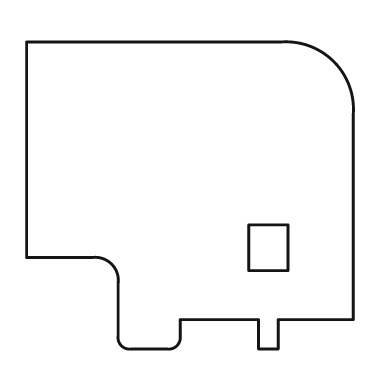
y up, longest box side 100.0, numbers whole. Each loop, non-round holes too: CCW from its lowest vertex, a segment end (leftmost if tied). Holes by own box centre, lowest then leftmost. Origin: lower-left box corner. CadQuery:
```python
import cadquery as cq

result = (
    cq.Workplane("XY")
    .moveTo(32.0, 0.0)
    .lineTo(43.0, 0.0)
    .threePointArc((46.0, 1.0), (47.0, 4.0))
    .lineTo(47.0, 9.0)
    .lineTo(71.0, 9.0)
    .lineTo(71.0, 0.0)
    .lineTo(77.0, 0.0)
    .lineTo(77.0, 9.0)
    .lineTo(100.0, 9.0)
    .lineTo(100.0, 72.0)
    .threePointArc((94.0, 88.0), (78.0, 94.0))
    .lineTo(0.0, 94.0)
    .lineTo(0.0, 28.0)
    .lineTo(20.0, 28.0)
    .threePointArc((26.0, 26.0), (28.0, 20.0))
    .lineTo(28.0, 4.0)
    .threePointArc((29.0, 1.0), (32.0, 0.0))
    .close()
    .moveTo(68.0, 24.0)
    .lineTo(80.0, 24.0)
    .lineTo(80.0, 38.0)
    .lineTo(68.0, 38.0)
    .close()
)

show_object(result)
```